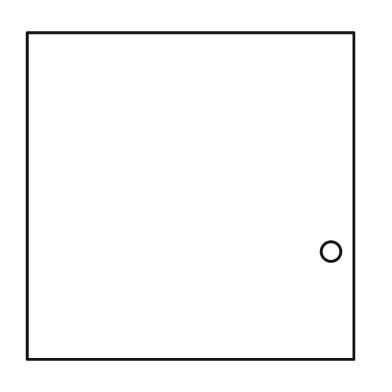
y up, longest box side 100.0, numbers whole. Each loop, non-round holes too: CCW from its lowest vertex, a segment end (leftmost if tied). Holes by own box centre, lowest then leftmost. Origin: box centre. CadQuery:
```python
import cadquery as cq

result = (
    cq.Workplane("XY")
    .moveTo(-50.0, -50.0)
    .lineTo(50.0, -50.0)
    .lineTo(50.0, 50.0)
    .lineTo(-50.0, 50.0)
    .close()
    .moveTo(43.0, -17.0)
    .circle(3.0)
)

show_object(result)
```